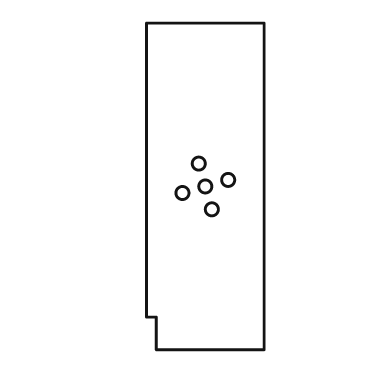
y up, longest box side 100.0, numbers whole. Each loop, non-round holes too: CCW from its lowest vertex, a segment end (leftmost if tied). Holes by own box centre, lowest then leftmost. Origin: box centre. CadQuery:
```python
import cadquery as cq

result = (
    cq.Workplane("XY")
    .moveTo(-15.0, -50.0)
    .lineTo(18.0, -50.0)
    .lineTo(18.0, 50.0)
    .lineTo(-18.0, 50.0)
    .lineTo(-18.0, -40.0)
    .lineTo(-15.0, -40.0)
    .close()
    .moveTo(2.0, -7.0)
    .circle(2.0)
    .moveTo(-7.0, -2.0)
    .circle(2.0)
    .moveTo(0.0, 0.0)
    .circle(2.0)
    .moveTo(7.0, 2.0)
    .circle(2.0)
    .moveTo(-2.0, 7.0)
    .circle(2.0)
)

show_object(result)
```